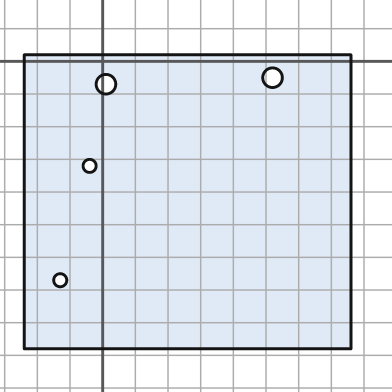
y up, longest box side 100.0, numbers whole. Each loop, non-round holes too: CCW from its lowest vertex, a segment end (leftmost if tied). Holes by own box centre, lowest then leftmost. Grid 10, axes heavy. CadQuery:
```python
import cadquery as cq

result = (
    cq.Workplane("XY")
    .moveTo(-24.0, -88.0)
    .lineTo(76.0, -88.0)
    .lineTo(76.0, 2.0)
    .lineTo(-24.0, 2.0)
    .close()
    .moveTo(-13.0, -67.0)
    .circle(2.0)
    .moveTo(-4.0, -32.0)
    .circle(2.0)
    .moveTo(1.0, -7.0)
    .circle(3.0)
    .moveTo(52.0, -5.0)
    .circle(3.0)
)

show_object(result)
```